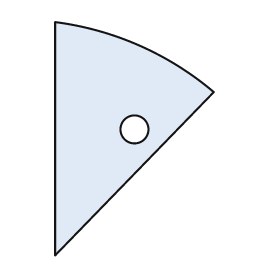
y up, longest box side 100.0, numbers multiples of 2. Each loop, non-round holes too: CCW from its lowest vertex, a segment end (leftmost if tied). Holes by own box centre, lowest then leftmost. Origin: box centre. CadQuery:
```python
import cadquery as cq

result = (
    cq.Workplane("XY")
    .moveTo(-34.0, -50.0)
    .lineTo(34.0, 20.0)
    .threePointArc((2.0, 40.0), (-34.0, 50.0))
    .close()
    .moveTo(0.0, 4.0)
    .circle(6.0)
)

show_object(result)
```